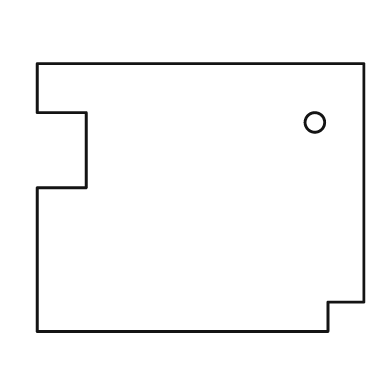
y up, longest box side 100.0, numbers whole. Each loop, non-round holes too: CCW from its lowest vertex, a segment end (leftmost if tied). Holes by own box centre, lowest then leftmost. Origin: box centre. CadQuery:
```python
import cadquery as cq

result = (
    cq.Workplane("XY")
    .moveTo(-50.0, -41.0)
    .lineTo(39.0, -41.0)
    .lineTo(39.0, -32.0)
    .lineTo(50.0, -32.0)
    .lineTo(50.0, 41.0)
    .lineTo(-50.0, 41.0)
    .lineTo(-50.0, 26.0)
    .lineTo(-35.0, 26.0)
    .lineTo(-35.0, 3.0)
    .lineTo(-50.0, 3.0)
    .close()
    .moveTo(35.0, 23.0)
    .circle(3.0)
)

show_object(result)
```